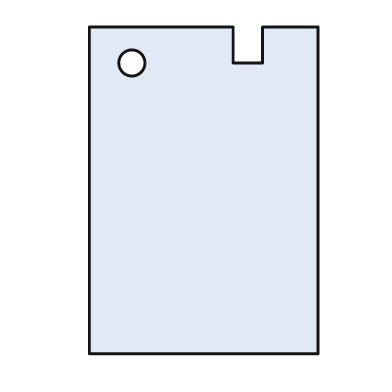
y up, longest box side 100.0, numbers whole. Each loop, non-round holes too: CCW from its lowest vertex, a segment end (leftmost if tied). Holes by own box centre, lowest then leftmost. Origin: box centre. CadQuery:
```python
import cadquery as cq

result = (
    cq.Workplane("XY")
    .moveTo(-35.0, -50.0)
    .lineTo(35.0, -50.0)
    .lineTo(35.0, 50.0)
    .lineTo(18.0, 50.0)
    .lineTo(18.0, 39.0)
    .lineTo(9.0, 39.0)
    .lineTo(9.0, 50.0)
    .lineTo(-35.0, 50.0)
    .close()
    .moveTo(-22.0, 39.0)
    .circle(4.0)
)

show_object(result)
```